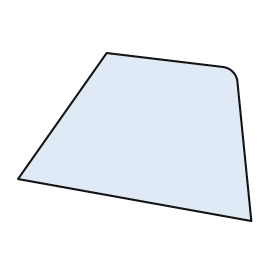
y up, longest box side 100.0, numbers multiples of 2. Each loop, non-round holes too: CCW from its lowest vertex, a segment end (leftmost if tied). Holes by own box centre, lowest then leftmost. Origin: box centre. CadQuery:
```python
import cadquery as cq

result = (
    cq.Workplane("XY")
    .moveTo(50.0, -36.0)
    .lineTo(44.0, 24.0)
    .threePointArc((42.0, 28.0), (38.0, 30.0))
    .lineTo(-12.0, 36.0)
    .lineTo(-50.0, -18.0)
    .close()
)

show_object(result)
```